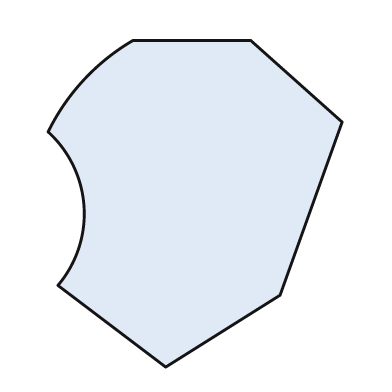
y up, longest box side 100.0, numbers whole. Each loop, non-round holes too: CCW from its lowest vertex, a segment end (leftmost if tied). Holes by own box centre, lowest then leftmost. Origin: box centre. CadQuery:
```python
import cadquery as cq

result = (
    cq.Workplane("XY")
    .moveTo(-9.0, -50.0)
    .lineTo(26.0, -28.0)
    .lineTo(45.0, 25.0)
    .lineTo(17.0, 50.0)
    .lineTo(-19.0, 50.0)
    .threePointArc((-34.0, 38.0), (-45.0, 22.0))
    .threePointArc((-34.0, -1.0), (-42.0, -25.0))
    .close()
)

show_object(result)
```